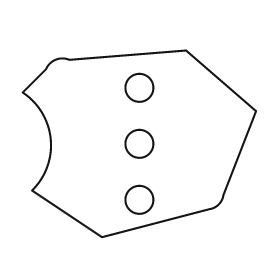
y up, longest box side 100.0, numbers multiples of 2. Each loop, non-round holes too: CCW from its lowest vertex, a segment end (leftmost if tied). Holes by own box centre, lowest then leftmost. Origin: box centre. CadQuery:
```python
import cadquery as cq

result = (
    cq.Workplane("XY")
    .moveTo(-16.0, -40.0)
    .lineTo(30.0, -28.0)
    .threePointArc((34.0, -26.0), (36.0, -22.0))
    .lineTo(50.0, 14.0)
    .lineTo(20.0, 40.0)
    .lineTo(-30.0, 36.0)
    .threePointArc((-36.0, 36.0), (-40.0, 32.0))
    .lineTo(-50.0, 22.0)
    .threePointArc((-38.0, 2.0), (-46.0, -20.0))
    .close()
    .moveTo(0.0, -24.0)
    .circle(6.0)
    .moveTo(0.0, 0.0)
    .circle(6.0)
    .moveTo(0.0, 24.0)
    .circle(6.0)
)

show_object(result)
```